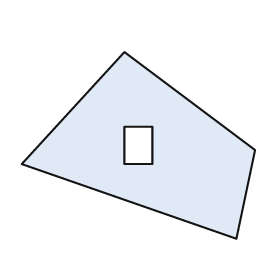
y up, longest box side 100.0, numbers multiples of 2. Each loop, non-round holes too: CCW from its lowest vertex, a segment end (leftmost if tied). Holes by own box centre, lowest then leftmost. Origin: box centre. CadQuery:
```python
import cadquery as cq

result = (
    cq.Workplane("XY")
    .moveTo(42.0, -40.0)
    .lineTo(50.0, -2.0)
    .lineTo(-6.0, 40.0)
    .lineTo(-50.0, -8.0)
    .close()
    .moveTo(-6.0, -8.0)
    .lineTo(6.0, -8.0)
    .lineTo(6.0, 8.0)
    .lineTo(-6.0, 8.0)
    .close()
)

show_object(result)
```